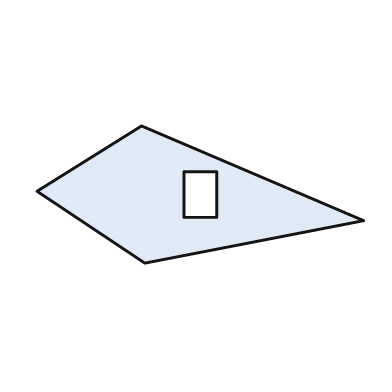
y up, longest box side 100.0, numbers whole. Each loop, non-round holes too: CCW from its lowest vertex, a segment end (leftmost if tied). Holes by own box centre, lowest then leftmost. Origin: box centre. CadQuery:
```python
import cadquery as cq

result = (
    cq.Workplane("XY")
    .moveTo(-17.0, -21.0)
    .lineTo(50.0, -8.0)
    .lineTo(-18.0, 21.0)
    .lineTo(-50.0, 1.0)
    .close()
    .moveTo(-5.0, -7.0)
    .lineTo(5.0, -7.0)
    .lineTo(5.0, 7.0)
    .lineTo(-5.0, 7.0)
    .close()
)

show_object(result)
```